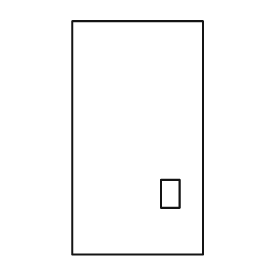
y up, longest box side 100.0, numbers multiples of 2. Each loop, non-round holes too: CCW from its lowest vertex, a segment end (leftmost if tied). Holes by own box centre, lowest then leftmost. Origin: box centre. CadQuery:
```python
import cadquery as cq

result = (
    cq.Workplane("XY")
    .moveTo(-28.0, -50.0)
    .lineTo(28.0, -50.0)
    .lineTo(28.0, 50.0)
    .lineTo(-28.0, 50.0)
    .close()
    .moveTo(10.0, -30.0)
    .lineTo(18.0, -30.0)
    .lineTo(18.0, -18.0)
    .lineTo(10.0, -18.0)
    .close()
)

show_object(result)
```